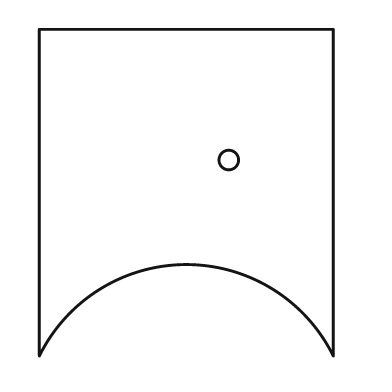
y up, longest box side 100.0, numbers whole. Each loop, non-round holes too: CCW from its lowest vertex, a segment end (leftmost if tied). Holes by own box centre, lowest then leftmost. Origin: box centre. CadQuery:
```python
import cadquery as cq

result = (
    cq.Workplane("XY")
    .moveTo(-45.0, -50.0)
    .threePointArc((0.0, -22.0), (45.0, -50.0))
    .lineTo(45.0, 50.0)
    .lineTo(-45.0, 50.0)
    .close()
    .moveTo(13.0, 10.0)
    .circle(3.0)
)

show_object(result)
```